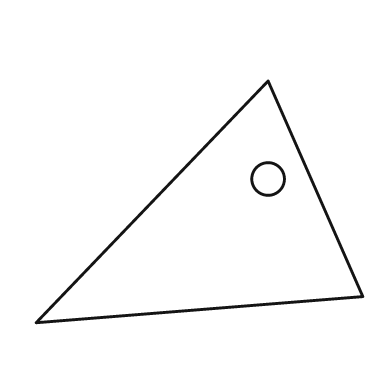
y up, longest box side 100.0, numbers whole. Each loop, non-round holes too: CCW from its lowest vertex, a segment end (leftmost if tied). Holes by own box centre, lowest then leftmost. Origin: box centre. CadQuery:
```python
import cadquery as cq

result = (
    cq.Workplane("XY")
    .moveTo(-50.0, -37.0)
    .lineTo(50.0, -29.0)
    .lineTo(21.0, 37.0)
    .close()
    .moveTo(21.0, 7.0)
    .circle(5.0)
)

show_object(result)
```